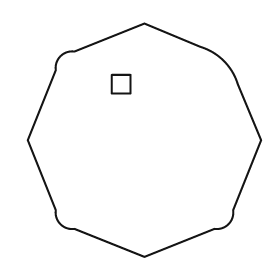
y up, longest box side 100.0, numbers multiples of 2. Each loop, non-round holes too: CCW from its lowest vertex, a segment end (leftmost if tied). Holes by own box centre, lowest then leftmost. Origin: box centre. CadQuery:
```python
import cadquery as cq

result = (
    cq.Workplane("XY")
    .moveTo(0.0, -50.0)
    .lineTo(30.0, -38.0)
    .threePointArc((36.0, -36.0), (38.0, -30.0))
    .lineTo(50.0, 0.0)
    .lineTo(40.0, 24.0)
    .threePointArc((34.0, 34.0), (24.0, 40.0))
    .lineTo(0.0, 50.0)
    .lineTo(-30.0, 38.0)
    .threePointArc((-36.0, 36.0), (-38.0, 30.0))
    .lineTo(-50.0, 0.0)
    .lineTo(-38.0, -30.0)
    .threePointArc((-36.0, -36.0), (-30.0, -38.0))
    .close()
    .moveTo(-14.0, 20.0)
    .lineTo(-6.0, 20.0)
    .lineTo(-6.0, 28.0)
    .lineTo(-14.0, 28.0)
    .close()
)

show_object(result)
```